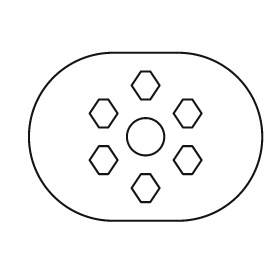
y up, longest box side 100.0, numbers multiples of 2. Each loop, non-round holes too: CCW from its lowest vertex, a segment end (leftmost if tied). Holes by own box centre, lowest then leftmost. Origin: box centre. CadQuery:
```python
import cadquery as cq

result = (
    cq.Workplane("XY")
    .moveTo(-14.0, -36.0)
    .lineTo(14.0, -36.0)
    .threePointArc((50.0, 0.0), (14.0, 36.0))
    .lineTo(-14.0, 36.0)
    .threePointArc((-50.0, 0.0), (-14.0, -36.0))
    .close()
    .moveTo(-2.0, -28.0)
    .lineTo(2.0, -28.0)
    .lineTo(6.0, -22.0)
    .lineTo(2.0, -16.0)
    .lineTo(-2.0, -16.0)
    .lineTo(-6.0, -22.0)
    .close()
    .moveTo(-20.0, -16.0)
    .lineTo(-16.0, -16.0)
    .lineTo(-12.0, -10.0)
    .lineTo(-16.0, -4.0)
    .lineTo(-20.0, -4.0)
    .lineTo(-24.0, -10.0)
    .close()
    .moveTo(16.0, -16.0)
    .lineTo(20.0, -16.0)
    .lineTo(24.0, -10.0)
    .lineTo(20.0, -4.0)
    .lineTo(16.0, -4.0)
    .lineTo(12.0, -10.0)
    .close()
    .moveTo(0.0, 0.0)
    .circle(8.0)
    .moveTo(-20.0, 4.0)
    .lineTo(-16.0, 4.0)
    .lineTo(-12.0, 10.0)
    .lineTo(-16.0, 16.0)
    .lineTo(-20.0, 16.0)
    .lineTo(-24.0, 10.0)
    .close()
    .moveTo(16.0, 4.0)
    .lineTo(20.0, 4.0)
    .lineTo(24.0, 10.0)
    .lineTo(20.0, 16.0)
    .lineTo(16.0, 16.0)
    .lineTo(12.0, 10.0)
    .close()
    .moveTo(-2.0, 16.0)
    .lineTo(2.0, 16.0)
    .lineTo(6.0, 22.0)
    .lineTo(2.0, 28.0)
    .lineTo(-2.0, 28.0)
    .lineTo(-6.0, 22.0)
    .close()
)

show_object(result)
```